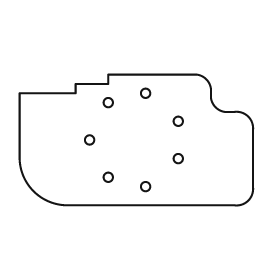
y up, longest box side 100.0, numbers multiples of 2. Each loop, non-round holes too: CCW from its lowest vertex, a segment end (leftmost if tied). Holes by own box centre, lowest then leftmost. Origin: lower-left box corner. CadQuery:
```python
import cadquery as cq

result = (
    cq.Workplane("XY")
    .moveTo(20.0, 0.0)
    .lineTo(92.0, 0.0)
    .threePointArc((98.0, 2.0), (100.0, 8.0))
    .lineTo(100.0, 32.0)
    .threePointArc((98.0, 38.0), (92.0, 40.0))
    .lineTo(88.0, 40.0)
    .threePointArc((84.0, 42.0), (82.0, 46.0))
    .lineTo(82.0, 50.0)
    .threePointArc((80.0, 54.0), (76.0, 56.0))
    .lineTo(38.0, 56.0)
    .lineTo(38.0, 52.0)
    .lineTo(24.0, 52.0)
    .lineTo(24.0, 48.0)
    .lineTo(0.0, 48.0)
    .lineTo(0.0, 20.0)
    .threePointArc((6.0, 6.0), (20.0, 0.0))
    .close()
    .moveTo(54.0, 8.0)
    .circle(2.0)
    .moveTo(38.0, 12.0)
    .circle(2.0)
    .moveTo(68.0, 20.0)
    .circle(2.0)
    .moveTo(30.0, 28.0)
    .circle(2.0)
    .moveTo(68.0, 36.0)
    .circle(2.0)
    .moveTo(38.0, 44.0)
    .circle(2.0)
    .moveTo(54.0, 48.0)
    .circle(2.0)
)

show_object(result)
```